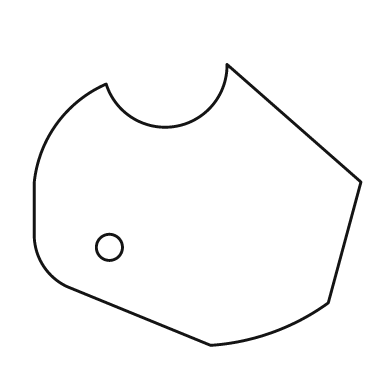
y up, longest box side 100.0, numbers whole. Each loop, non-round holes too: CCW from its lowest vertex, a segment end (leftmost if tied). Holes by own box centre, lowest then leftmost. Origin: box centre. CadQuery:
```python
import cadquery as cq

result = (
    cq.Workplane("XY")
    .moveTo(4.0, -43.0)
    .threePointArc((23.0, -39.0), (40.0, -30.0))
    .lineTo(50.0, 7.0)
    .lineTo(9.0, 43.0)
    .threePointArc((-7.0, 24.0), (-28.0, 37.0))
    .threePointArc((-43.0, 25.0), (-50.0, 7.0))
    .lineTo(-50.0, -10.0)
    .threePointArc((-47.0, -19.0), (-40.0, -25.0))
    .close()
    .moveTo(-27.0, -13.0)
    .circle(4.0)
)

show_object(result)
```